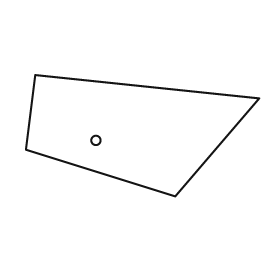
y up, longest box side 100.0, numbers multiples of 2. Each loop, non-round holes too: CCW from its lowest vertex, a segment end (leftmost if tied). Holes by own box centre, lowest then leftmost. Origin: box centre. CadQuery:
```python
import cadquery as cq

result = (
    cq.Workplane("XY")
    .moveTo(14.0, -26.0)
    .lineTo(50.0, 16.0)
    .lineTo(-46.0, 26.0)
    .lineTo(-50.0, -6.0)
    .close()
    .moveTo(-20.0, -2.0)
    .circle(2.0)
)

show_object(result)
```